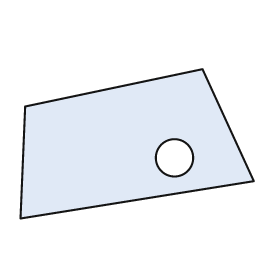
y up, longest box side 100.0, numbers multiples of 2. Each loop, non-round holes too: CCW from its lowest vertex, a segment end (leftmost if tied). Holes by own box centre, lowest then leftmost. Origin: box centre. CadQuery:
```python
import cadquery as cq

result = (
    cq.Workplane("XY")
    .moveTo(-50.0, -32.0)
    .lineTo(50.0, -16.0)
    .lineTo(28.0, 32.0)
    .lineTo(-48.0, 16.0)
    .close()
    .moveTo(16.0, -6.0)
    .circle(8.0)
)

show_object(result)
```